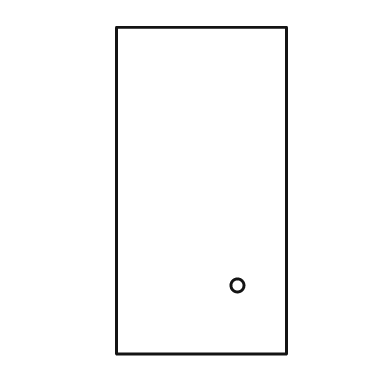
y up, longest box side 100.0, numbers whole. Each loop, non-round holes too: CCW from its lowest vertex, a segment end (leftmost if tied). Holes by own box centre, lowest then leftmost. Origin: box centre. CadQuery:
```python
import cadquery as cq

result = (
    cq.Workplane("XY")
    .moveTo(-26.0, -50.0)
    .lineTo(26.0, -50.0)
    .lineTo(26.0, 50.0)
    .lineTo(-26.0, 50.0)
    .close()
    .moveTo(11.0, -29.0)
    .circle(2.0)
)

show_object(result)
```